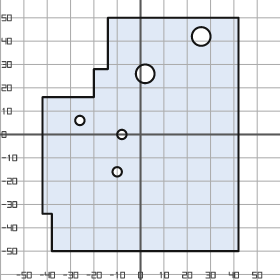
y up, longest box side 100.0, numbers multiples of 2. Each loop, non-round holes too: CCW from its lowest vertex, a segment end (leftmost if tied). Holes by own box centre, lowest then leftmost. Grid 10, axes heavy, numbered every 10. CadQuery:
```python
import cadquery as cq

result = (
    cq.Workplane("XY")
    .moveTo(-38.0, -50.0)
    .lineTo(42.0, -50.0)
    .lineTo(42.0, 50.0)
    .lineTo(-14.0, 50.0)
    .lineTo(-14.0, 28.0)
    .lineTo(-20.0, 28.0)
    .lineTo(-20.0, 16.0)
    .lineTo(-42.0, 16.0)
    .lineTo(-42.0, -34.0)
    .lineTo(-38.0, -34.0)
    .close()
    .moveTo(-10.0, -16.0)
    .circle(2.0)
    .moveTo(-8.0, 0.0)
    .circle(2.0)
    .moveTo(-26.0, 6.0)
    .circle(2.0)
    .moveTo(2.0, 26.0)
    .circle(4.0)
    .moveTo(26.0, 42.0)
    .circle(4.0)
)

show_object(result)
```